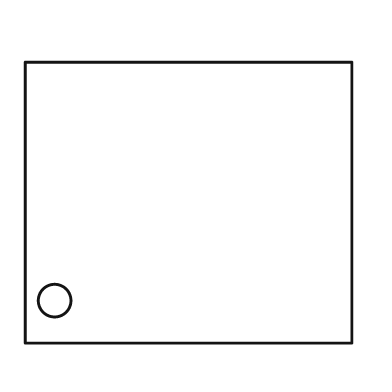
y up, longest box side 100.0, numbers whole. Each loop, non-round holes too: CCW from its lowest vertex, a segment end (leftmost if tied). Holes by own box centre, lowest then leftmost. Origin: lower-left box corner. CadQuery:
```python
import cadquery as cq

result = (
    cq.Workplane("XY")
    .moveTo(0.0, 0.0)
    .lineTo(100.0, 0.0)
    .lineTo(100.0, 86.0)
    .lineTo(0.0, 86.0)
    .close()
    .moveTo(9.0, 13.0)
    .circle(5.0)
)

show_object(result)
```